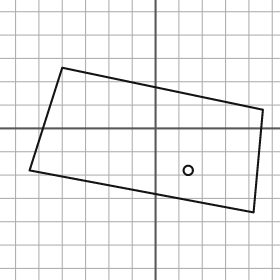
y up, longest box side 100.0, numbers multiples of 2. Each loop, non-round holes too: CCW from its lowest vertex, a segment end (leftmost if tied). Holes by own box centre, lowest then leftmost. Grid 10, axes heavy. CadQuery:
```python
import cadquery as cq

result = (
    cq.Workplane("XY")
    .moveTo(42.0, -36.0)
    .lineTo(46.0, 8.0)
    .lineTo(-40.0, 26.0)
    .lineTo(-54.0, -18.0)
    .close()
    .moveTo(14.0, -18.0)
    .circle(2.0)
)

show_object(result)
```